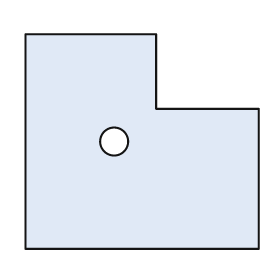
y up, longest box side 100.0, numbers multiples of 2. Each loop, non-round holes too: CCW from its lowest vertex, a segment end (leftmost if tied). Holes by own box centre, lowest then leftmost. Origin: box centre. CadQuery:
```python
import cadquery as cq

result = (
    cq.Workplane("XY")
    .moveTo(-50.0, -46.0)
    .lineTo(50.0, -46.0)
    .lineTo(50.0, 14.0)
    .lineTo(6.0, 14.0)
    .lineTo(6.0, 46.0)
    .lineTo(-50.0, 46.0)
    .close()
    .moveTo(-12.0, 0.0)
    .circle(6.0)
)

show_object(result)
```